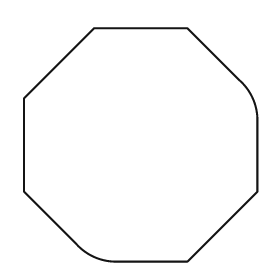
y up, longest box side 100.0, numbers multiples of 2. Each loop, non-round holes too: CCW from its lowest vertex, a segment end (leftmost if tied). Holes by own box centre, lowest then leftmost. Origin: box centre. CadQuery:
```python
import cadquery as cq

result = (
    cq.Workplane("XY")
    .moveTo(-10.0, -50.0)
    .lineTo(20.0, -50.0)
    .lineTo(50.0, -20.0)
    .lineTo(50.0, 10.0)
    .threePointArc((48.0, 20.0), (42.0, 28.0))
    .lineTo(20.0, 50.0)
    .lineTo(-20.0, 50.0)
    .lineTo(-50.0, 20.0)
    .lineTo(-50.0, -20.0)
    .lineTo(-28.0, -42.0)
    .threePointArc((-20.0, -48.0), (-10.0, -50.0))
    .close()
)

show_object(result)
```